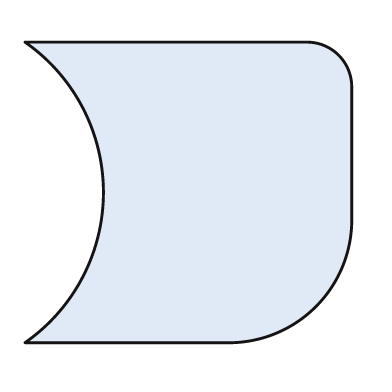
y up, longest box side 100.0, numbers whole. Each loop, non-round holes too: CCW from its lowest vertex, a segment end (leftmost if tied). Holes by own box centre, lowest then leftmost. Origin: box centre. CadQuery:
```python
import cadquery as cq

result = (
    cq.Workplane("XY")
    .moveTo(-50.0, -46.0)
    .lineTo(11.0, -46.0)
    .threePointArc((39.0, -35.0), (50.0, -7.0))
    .lineTo(50.0, 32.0)
    .threePointArc((46.0, 42.0), (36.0, 46.0))
    .lineTo(-50.0, 46.0)
    .threePointArc((-26.0, 0.0), (-50.0, -46.0))
    .close()
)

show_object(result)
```